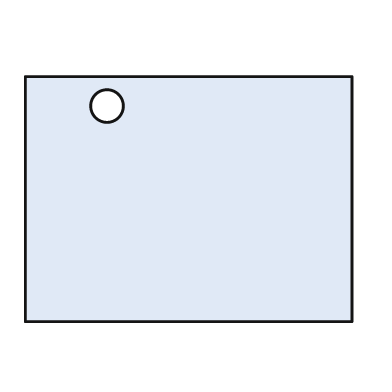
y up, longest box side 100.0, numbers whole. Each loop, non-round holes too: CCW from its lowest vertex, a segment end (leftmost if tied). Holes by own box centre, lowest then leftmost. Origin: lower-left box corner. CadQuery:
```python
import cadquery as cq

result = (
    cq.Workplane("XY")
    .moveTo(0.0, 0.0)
    .lineTo(100.0, 0.0)
    .lineTo(100.0, 75.0)
    .lineTo(0.0, 75.0)
    .close()
    .moveTo(25.0, 66.0)
    .circle(5.0)
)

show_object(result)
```